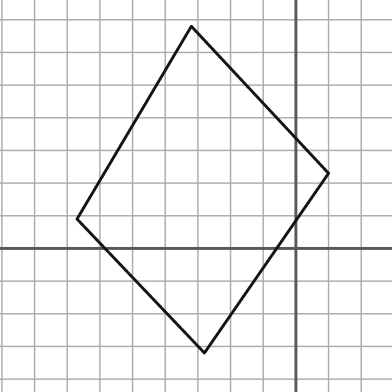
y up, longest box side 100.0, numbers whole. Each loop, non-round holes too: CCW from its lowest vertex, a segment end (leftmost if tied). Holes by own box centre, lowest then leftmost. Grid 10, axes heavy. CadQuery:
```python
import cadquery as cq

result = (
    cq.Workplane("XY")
    .moveTo(-28.0, -32.0)
    .lineTo(10.0, 23.0)
    .lineTo(-32.0, 68.0)
    .lineTo(-67.0, 9.0)
    .close()
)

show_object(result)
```